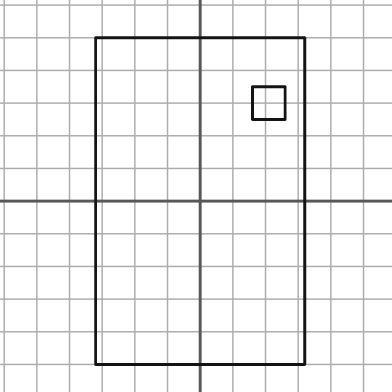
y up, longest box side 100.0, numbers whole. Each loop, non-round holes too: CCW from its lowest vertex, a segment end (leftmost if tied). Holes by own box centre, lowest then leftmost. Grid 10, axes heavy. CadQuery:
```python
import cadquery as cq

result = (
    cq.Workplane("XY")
    .moveTo(-32.0, -50.0)
    .lineTo(32.0, -50.0)
    .lineTo(32.0, 50.0)
    .lineTo(-32.0, 50.0)
    .close()
    .moveTo(16.0, 25.0)
    .lineTo(26.0, 25.0)
    .lineTo(26.0, 35.0)
    .lineTo(16.0, 35.0)
    .close()
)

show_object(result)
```